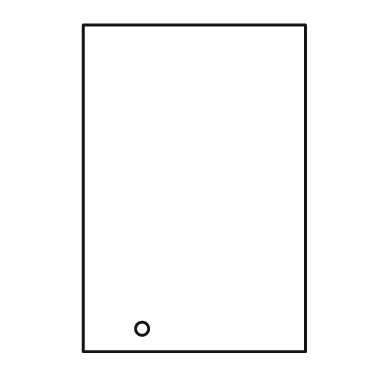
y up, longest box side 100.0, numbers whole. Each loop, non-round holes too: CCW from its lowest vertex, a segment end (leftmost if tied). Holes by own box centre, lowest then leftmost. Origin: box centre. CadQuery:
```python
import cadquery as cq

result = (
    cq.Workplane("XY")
    .moveTo(-34.0, -50.0)
    .lineTo(34.0, -50.0)
    .lineTo(34.0, 50.0)
    .lineTo(-34.0, 50.0)
    .close()
    .moveTo(-16.0, -43.0)
    .circle(2.0)
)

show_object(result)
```